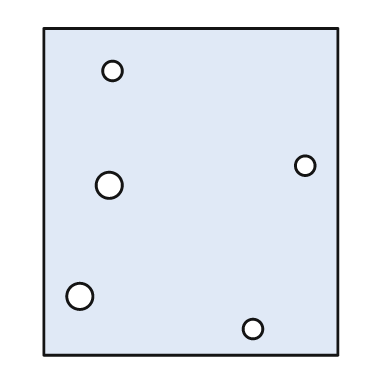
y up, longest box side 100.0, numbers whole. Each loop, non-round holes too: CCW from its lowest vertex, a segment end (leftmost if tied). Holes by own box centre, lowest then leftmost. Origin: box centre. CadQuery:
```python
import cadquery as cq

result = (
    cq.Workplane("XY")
    .moveTo(-45.0, -50.0)
    .lineTo(45.0, -50.0)
    .lineTo(45.0, 50.0)
    .lineTo(-45.0, 50.0)
    .close()
    .moveTo(19.0, -42.0)
    .circle(3.0)
    .moveTo(-34.0, -32.0)
    .circle(4.0)
    .moveTo(-25.0, 2.0)
    .circle(4.0)
    .moveTo(35.0, 8.0)
    .circle(3.0)
    .moveTo(-24.0, 37.0)
    .circle(3.0)
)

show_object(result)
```